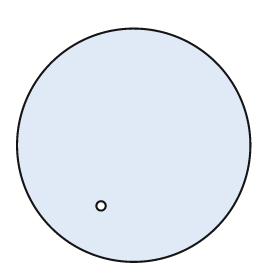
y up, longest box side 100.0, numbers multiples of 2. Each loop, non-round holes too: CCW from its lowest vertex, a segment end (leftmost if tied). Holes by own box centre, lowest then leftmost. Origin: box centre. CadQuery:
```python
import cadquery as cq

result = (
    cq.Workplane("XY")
    .moveTo(0.0, 0.0)
    .circle(50.0)
    .moveTo(-14.0, -26.0)
    .circle(2.0)
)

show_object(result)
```